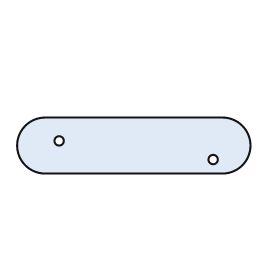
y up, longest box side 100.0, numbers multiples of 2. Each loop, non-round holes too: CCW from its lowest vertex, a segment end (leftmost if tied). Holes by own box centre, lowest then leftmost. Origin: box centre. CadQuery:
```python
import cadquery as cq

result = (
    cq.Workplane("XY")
    .moveTo(-38.0, -12.0)
    .lineTo(38.0, -12.0)
    .threePointArc((50.0, 0.0), (38.0, 12.0))
    .lineTo(-38.0, 12.0)
    .threePointArc((-50.0, 0.0), (-38.0, -12.0))
    .close()
    .moveTo(34.0, -6.0)
    .circle(2.0)
    .moveTo(-32.0, 2.0)
    .circle(2.0)
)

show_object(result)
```